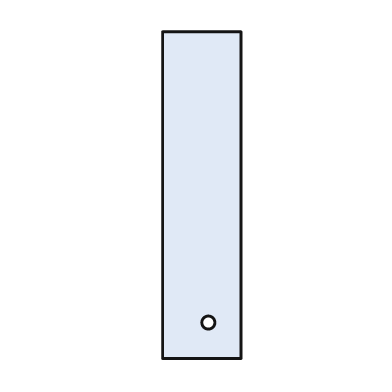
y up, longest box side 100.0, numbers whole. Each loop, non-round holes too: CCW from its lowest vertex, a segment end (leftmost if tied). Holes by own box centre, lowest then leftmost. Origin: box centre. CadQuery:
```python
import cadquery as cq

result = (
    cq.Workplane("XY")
    .moveTo(-12.0, -50.0)
    .lineTo(12.0, -50.0)
    .lineTo(12.0, 50.0)
    .lineTo(-12.0, 50.0)
    .close()
    .moveTo(2.0, -39.0)
    .circle(2.0)
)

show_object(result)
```